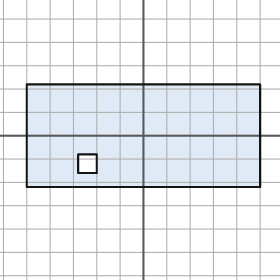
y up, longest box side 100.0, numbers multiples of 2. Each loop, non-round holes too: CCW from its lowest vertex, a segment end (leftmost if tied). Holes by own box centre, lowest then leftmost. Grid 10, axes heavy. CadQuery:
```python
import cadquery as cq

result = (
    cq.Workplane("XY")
    .moveTo(-50.0, -22.0)
    .lineTo(50.0, -22.0)
    .lineTo(50.0, 22.0)
    .lineTo(-50.0, 22.0)
    .close()
    .moveTo(-28.0, -16.0)
    .lineTo(-20.0, -16.0)
    .lineTo(-20.0, -8.0)
    .lineTo(-28.0, -8.0)
    .close()
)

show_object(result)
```